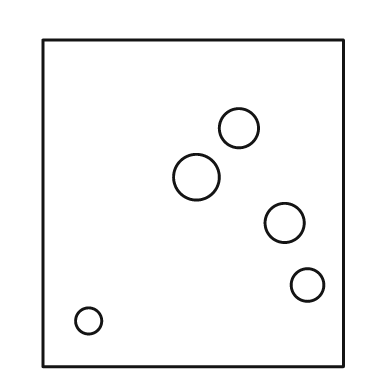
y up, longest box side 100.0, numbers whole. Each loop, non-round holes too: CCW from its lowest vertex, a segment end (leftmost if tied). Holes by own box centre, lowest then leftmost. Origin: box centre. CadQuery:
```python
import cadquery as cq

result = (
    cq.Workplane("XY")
    .moveTo(-46.0, -50.0)
    .lineTo(46.0, -50.0)
    .lineTo(46.0, 50.0)
    .lineTo(-46.0, 50.0)
    .close()
    .moveTo(-32.0, -36.0)
    .circle(4.0)
    .moveTo(35.0, -25.0)
    .circle(5.0)
    .moveTo(28.0, -6.0)
    .circle(6.0)
    .moveTo(1.0, 8.0)
    .circle(7.0)
    .moveTo(14.0, 23.0)
    .circle(6.0)
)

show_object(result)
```